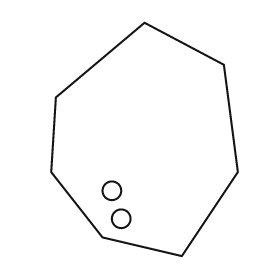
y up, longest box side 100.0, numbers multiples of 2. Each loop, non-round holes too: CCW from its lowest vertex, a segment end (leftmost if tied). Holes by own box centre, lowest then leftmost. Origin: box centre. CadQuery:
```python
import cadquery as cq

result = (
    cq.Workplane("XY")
    .moveTo(16.0, -50.0)
    .lineTo(40.0, -14.0)
    .lineTo(34.0, 32.0)
    .lineTo(0.0, 50.0)
    .lineTo(-38.0, 18.0)
    .lineTo(-40.0, -14.0)
    .lineTo(-18.0, -42.0)
    .close()
    .moveTo(-10.0, -34.0)
    .circle(4.0)
    .moveTo(-14.0, -22.0)
    .circle(4.0)
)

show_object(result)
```